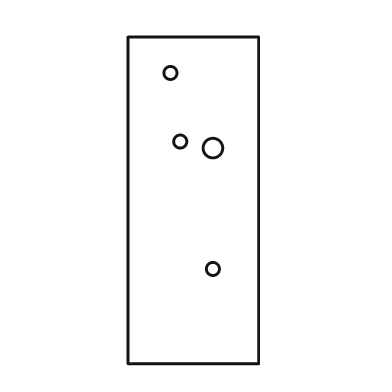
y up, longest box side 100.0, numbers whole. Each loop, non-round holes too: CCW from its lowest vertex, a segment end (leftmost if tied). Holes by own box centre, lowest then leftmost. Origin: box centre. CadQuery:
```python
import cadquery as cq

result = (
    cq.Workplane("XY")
    .moveTo(-20.0, -50.0)
    .lineTo(20.0, -50.0)
    .lineTo(20.0, 50.0)
    .lineTo(-20.0, 50.0)
    .close()
    .moveTo(6.0, -21.0)
    .circle(2.0)
    .moveTo(6.0, 16.0)
    .circle(3.0)
    .moveTo(-4.0, 18.0)
    .circle(2.0)
    .moveTo(-7.0, 39.0)
    .circle(2.0)
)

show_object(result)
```